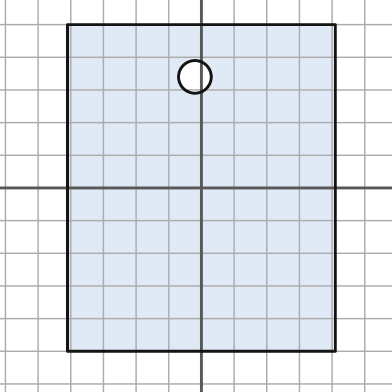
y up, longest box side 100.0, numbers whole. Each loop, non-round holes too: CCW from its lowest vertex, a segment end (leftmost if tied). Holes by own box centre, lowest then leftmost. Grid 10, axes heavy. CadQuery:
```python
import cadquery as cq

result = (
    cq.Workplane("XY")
    .moveTo(-41.0, -50.0)
    .lineTo(41.0, -50.0)
    .lineTo(41.0, 50.0)
    .lineTo(-41.0, 50.0)
    .close()
    .moveTo(-2.0, 34.0)
    .circle(5.0)
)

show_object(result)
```